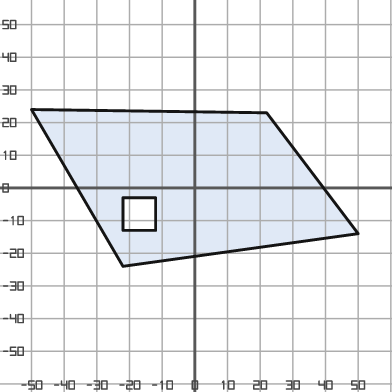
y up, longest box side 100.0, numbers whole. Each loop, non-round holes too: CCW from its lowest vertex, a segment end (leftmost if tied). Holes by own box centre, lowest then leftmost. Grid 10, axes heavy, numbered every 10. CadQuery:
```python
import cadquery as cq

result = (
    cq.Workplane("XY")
    .moveTo(-22.0, -24.0)
    .lineTo(50.0, -14.0)
    .lineTo(22.0, 23.0)
    .lineTo(-50.0, 24.0)
    .close()
    .moveTo(-22.0, -13.0)
    .lineTo(-12.0, -13.0)
    .lineTo(-12.0, -3.0)
    .lineTo(-22.0, -3.0)
    .close()
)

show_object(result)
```